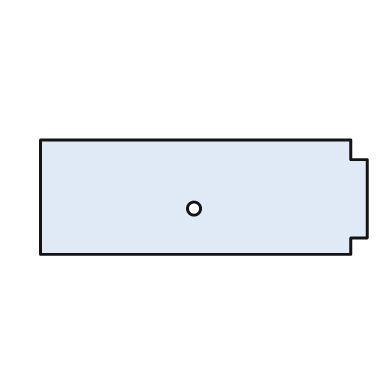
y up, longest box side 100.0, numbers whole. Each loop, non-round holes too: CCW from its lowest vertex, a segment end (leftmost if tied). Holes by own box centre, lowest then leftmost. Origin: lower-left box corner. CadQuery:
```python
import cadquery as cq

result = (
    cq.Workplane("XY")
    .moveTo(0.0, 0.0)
    .lineTo(95.0, 0.0)
    .lineTo(95.0, 5.0)
    .lineTo(100.0, 5.0)
    .lineTo(100.0, 29.0)
    .lineTo(95.0, 29.0)
    .lineTo(95.0, 35.0)
    .lineTo(0.0, 35.0)
    .close()
    .moveTo(47.0, 14.0)
    .circle(2.0)
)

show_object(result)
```